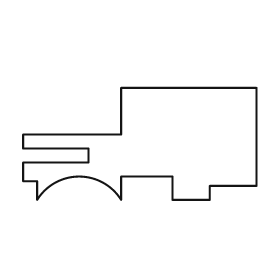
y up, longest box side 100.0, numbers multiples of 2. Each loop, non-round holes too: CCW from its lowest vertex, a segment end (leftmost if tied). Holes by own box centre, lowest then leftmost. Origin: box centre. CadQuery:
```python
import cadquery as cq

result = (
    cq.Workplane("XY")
    .moveTo(-44.0, -24.0)
    .threePointArc((-26.0, -14.0), (-8.0, -24.0))
    .lineTo(-8.0, -14.0)
    .lineTo(14.0, -14.0)
    .lineTo(14.0, -24.0)
    .lineTo(30.0, -24.0)
    .lineTo(30.0, -18.0)
    .lineTo(50.0, -18.0)
    .lineTo(50.0, 24.0)
    .lineTo(-8.0, 24.0)
    .lineTo(-8.0, 4.0)
    .lineTo(-50.0, 4.0)
    .lineTo(-50.0, -2.0)
    .lineTo(-22.0, -2.0)
    .lineTo(-22.0, -8.0)
    .lineTo(-50.0, -8.0)
    .lineTo(-50.0, -16.0)
    .lineTo(-44.0, -16.0)
    .close()
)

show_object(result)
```